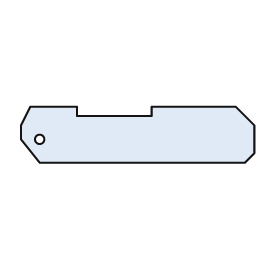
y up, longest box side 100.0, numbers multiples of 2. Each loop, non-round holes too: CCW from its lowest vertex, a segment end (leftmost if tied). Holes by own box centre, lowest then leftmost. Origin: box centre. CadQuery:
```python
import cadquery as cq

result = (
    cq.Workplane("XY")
    .moveTo(-42.0, -12.0)
    .lineTo(46.0, -12.0)
    .lineTo(50.0, -8.0)
    .lineTo(50.0, 4.0)
    .lineTo(42.0, 12.0)
    .lineTo(6.0, 12.0)
    .lineTo(6.0, 8.0)
    .lineTo(-26.0, 8.0)
    .lineTo(-26.0, 12.0)
    .lineTo(-46.0, 12.0)
    .lineTo(-50.0, 4.0)
    .lineTo(-50.0, -2.0)
    .close()
    .moveTo(-42.0, -2.0)
    .circle(2.0)
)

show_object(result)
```